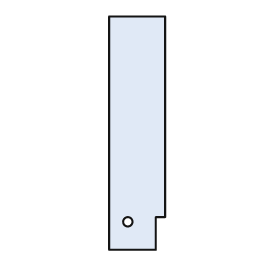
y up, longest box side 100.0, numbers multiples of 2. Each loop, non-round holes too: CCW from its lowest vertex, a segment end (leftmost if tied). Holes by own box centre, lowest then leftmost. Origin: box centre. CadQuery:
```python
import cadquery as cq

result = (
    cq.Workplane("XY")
    .moveTo(-12.0, -50.0)
    .lineTo(8.0, -50.0)
    .lineTo(8.0, -36.0)
    .lineTo(12.0, -36.0)
    .lineTo(12.0, 50.0)
    .lineTo(-12.0, 50.0)
    .close()
    .moveTo(-4.0, -38.0)
    .circle(2.0)
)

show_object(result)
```